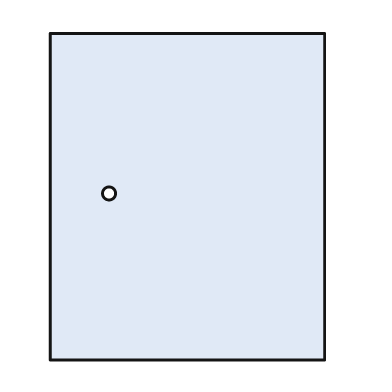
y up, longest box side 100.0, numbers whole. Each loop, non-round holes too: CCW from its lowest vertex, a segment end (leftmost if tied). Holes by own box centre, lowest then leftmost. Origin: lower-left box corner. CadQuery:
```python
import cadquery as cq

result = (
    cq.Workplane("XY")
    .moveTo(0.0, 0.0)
    .lineTo(84.0, 0.0)
    .lineTo(84.0, 100.0)
    .lineTo(0.0, 100.0)
    .close()
    .moveTo(18.0, 51.0)
    .circle(2.0)
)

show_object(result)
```